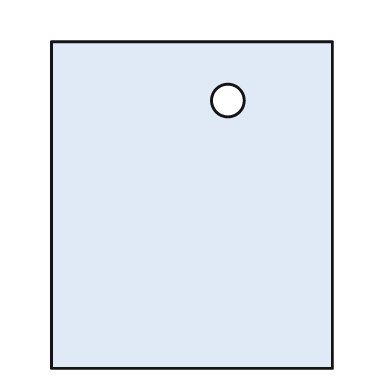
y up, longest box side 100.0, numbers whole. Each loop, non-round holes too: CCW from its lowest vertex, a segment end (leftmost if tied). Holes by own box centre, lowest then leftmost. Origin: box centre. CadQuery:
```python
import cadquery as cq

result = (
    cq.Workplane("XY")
    .moveTo(-43.0, -50.0)
    .lineTo(43.0, -50.0)
    .lineTo(43.0, 50.0)
    .lineTo(-43.0, 50.0)
    .close()
    .moveTo(11.0, 32.0)
    .circle(5.0)
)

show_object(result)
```